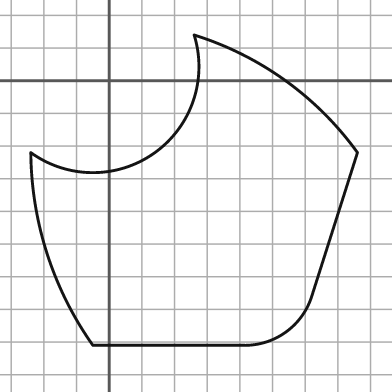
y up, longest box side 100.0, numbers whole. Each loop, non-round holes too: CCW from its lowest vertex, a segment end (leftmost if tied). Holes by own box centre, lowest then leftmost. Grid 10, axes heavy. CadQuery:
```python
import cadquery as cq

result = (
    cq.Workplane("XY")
    .moveTo(-5.0, -81.0)
    .lineTo(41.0, -81.0)
    .threePointArc((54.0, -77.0), (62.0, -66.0))
    .lineTo(76.0, -22.0)
    .threePointArc((54.0, 0.0), (26.0, 14.0))
    .threePointArc((14.0, -22.0), (-24.0, -22.0))
    .threePointArc((-19.0, -53.0), (-5.0, -81.0))
    .close()
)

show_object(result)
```